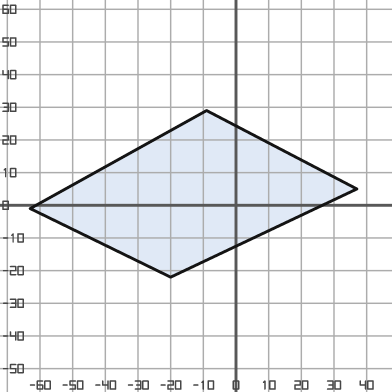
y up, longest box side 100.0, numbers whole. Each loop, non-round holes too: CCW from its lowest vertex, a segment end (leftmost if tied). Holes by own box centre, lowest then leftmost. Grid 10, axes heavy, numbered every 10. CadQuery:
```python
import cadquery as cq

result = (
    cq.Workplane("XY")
    .moveTo(-20.0, -22.0)
    .lineTo(37.0, 5.0)
    .lineTo(-9.0, 29.0)
    .lineTo(-63.0, -1.0)
    .close()
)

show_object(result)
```